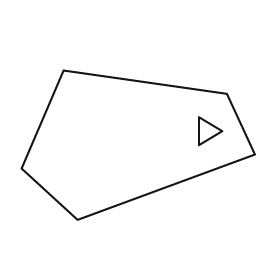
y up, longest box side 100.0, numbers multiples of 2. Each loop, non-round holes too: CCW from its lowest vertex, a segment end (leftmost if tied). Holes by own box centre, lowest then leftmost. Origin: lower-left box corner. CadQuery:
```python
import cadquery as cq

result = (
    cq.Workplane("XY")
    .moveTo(24.0, 0.0)
    .lineTo(100.0, 28.0)
    .lineTo(88.0, 54.0)
    .lineTo(18.0, 64.0)
    .lineTo(0.0, 22.0)
    .close()
    .moveTo(76.0, 32.0)
    .lineTo(86.0, 38.0)
    .lineTo(76.0, 44.0)
    .close()
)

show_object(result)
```